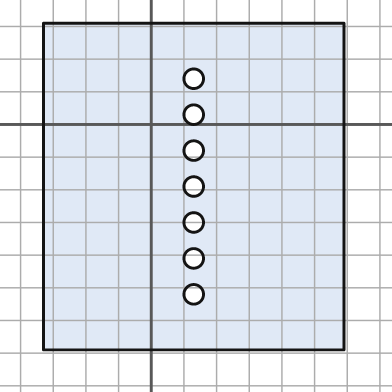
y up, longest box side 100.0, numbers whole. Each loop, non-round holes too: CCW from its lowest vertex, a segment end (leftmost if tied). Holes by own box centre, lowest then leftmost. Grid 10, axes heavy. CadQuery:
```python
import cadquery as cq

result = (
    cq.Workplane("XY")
    .moveTo(-33.0, -69.0)
    .lineTo(59.0, -69.0)
    .lineTo(59.0, 31.0)
    .lineTo(-33.0, 31.0)
    .close()
    .moveTo(13.0, -52.0)
    .circle(3.0)
    .moveTo(13.0, -41.0)
    .circle(3.0)
    .moveTo(13.0, -30.0)
    .circle(3.0)
    .moveTo(13.0, -19.0)
    .circle(3.0)
    .moveTo(13.0, -8.0)
    .circle(3.0)
    .moveTo(13.0, 3.0)
    .circle(3.0)
    .moveTo(13.0, 14.0)
    .circle(3.0)
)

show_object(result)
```